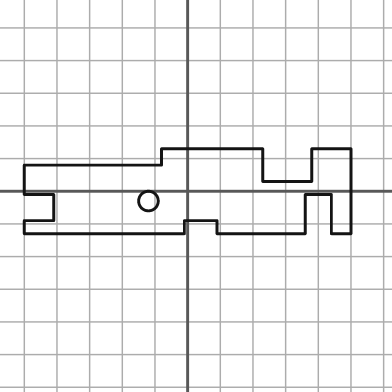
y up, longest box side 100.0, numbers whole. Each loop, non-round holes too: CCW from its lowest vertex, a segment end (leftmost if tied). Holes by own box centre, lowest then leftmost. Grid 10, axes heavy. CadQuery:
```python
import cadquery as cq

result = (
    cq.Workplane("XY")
    .moveTo(-50.0, -13.0)
    .lineTo(-1.0, -13.0)
    .lineTo(-1.0, -9.0)
    .lineTo(9.0, -9.0)
    .lineTo(9.0, -13.0)
    .lineTo(36.0, -13.0)
    .lineTo(36.0, -1.0)
    .lineTo(44.0, -1.0)
    .lineTo(44.0, -13.0)
    .lineTo(50.0, -13.0)
    .lineTo(50.0, 13.0)
    .lineTo(38.0, 13.0)
    .lineTo(38.0, 3.0)
    .lineTo(23.0, 3.0)
    .lineTo(23.0, 13.0)
    .lineTo(-8.0, 13.0)
    .lineTo(-8.0, 8.0)
    .lineTo(-50.0, 8.0)
    .lineTo(-50.0, -1.0)
    .lineTo(-41.0, -1.0)
    .lineTo(-41.0, -9.0)
    .lineTo(-50.0, -9.0)
    .close()
    .moveTo(-12.0, -3.0)
    .circle(3.0)
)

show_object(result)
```